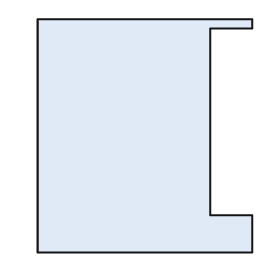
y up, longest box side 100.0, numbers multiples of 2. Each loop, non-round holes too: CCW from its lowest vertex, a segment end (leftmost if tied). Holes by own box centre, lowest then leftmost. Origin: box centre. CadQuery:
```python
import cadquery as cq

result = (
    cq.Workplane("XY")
    .moveTo(-46.0, -50.0)
    .lineTo(46.0, -50.0)
    .lineTo(46.0, -34.0)
    .lineTo(28.0, -34.0)
    .lineTo(28.0, 46.0)
    .lineTo(46.0, 46.0)
    .lineTo(46.0, 50.0)
    .lineTo(-46.0, 50.0)
    .close()
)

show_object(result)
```